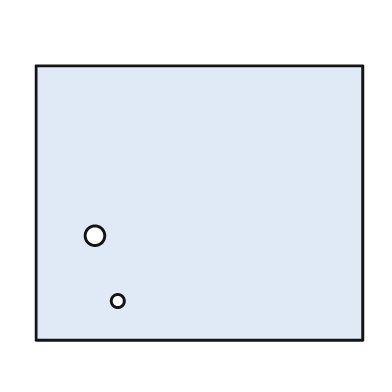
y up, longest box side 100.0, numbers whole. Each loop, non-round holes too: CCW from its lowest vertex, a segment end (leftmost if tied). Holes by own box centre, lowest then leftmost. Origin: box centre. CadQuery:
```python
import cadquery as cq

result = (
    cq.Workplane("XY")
    .moveTo(-50.0, -42.0)
    .lineTo(50.0, -42.0)
    .lineTo(50.0, 42.0)
    .lineTo(-50.0, 42.0)
    .close()
    .moveTo(-25.0, -30.0)
    .circle(2.0)
    .moveTo(-32.0, -10.0)
    .circle(3.0)
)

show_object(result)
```